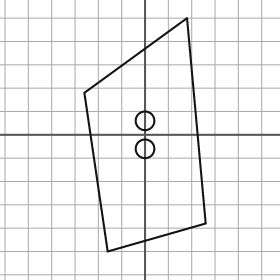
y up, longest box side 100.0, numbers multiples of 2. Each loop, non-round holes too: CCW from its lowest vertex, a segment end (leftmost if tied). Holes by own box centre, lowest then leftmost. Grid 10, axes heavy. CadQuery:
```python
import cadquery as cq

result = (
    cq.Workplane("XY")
    .moveTo(-16.0, -50.0)
    .lineTo(26.0, -38.0)
    .lineTo(18.0, 50.0)
    .lineTo(-26.0, 18.0)
    .close()
    .moveTo(0.0, -6.0)
    .circle(4.0)
    .moveTo(0.0, 6.0)
    .circle(4.0)
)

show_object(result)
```